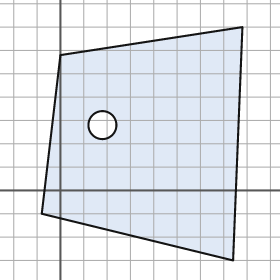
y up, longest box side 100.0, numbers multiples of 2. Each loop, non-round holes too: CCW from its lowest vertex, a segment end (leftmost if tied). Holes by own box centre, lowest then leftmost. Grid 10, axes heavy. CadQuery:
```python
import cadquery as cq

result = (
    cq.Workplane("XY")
    .moveTo(74.0, -30.0)
    .lineTo(78.0, 70.0)
    .lineTo(0.0, 58.0)
    .lineTo(-8.0, -10.0)
    .close()
    .moveTo(18.0, 28.0)
    .circle(6.0)
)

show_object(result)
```